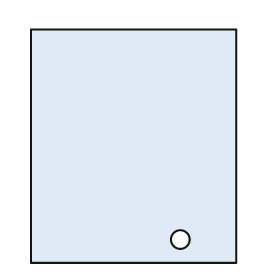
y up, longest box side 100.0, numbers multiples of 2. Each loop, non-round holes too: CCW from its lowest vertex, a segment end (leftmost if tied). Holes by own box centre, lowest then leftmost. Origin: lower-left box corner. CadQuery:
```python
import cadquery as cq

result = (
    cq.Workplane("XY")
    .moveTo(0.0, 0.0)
    .lineTo(88.0, 0.0)
    .lineTo(88.0, 100.0)
    .lineTo(0.0, 100.0)
    .close()
    .moveTo(64.0, 10.0)
    .circle(4.0)
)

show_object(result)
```